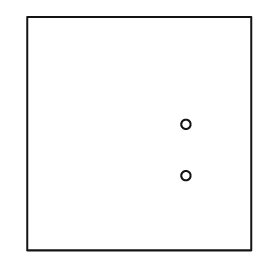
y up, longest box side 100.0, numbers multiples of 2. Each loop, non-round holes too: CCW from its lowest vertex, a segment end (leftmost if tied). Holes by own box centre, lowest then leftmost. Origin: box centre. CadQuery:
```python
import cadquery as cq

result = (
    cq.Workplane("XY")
    .moveTo(-48.0, -50.0)
    .lineTo(48.0, -50.0)
    .lineTo(48.0, 50.0)
    .lineTo(-48.0, 50.0)
    .close()
    .moveTo(20.0, -18.0)
    .circle(2.0)
    .moveTo(20.0, 4.0)
    .circle(2.0)
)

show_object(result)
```